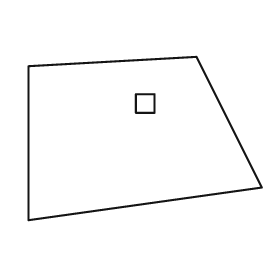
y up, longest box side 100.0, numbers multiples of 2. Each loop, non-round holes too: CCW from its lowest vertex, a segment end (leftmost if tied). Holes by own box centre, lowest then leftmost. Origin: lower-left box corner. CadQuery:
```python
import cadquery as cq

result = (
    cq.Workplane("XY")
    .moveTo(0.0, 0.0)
    .lineTo(100.0, 14.0)
    .lineTo(72.0, 70.0)
    .lineTo(0.0, 66.0)
    .close()
    .moveTo(46.0, 46.0)
    .lineTo(54.0, 46.0)
    .lineTo(54.0, 54.0)
    .lineTo(46.0, 54.0)
    .close()
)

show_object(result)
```